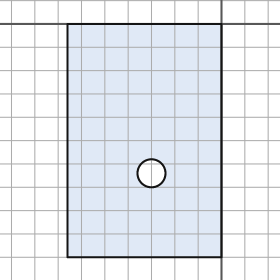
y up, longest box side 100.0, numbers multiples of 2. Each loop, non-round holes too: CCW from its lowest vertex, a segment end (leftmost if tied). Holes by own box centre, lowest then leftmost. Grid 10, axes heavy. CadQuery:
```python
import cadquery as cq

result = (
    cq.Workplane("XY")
    .moveTo(-66.0, -100.0)
    .lineTo(0.0, -100.0)
    .lineTo(0.0, 0.0)
    .lineTo(-66.0, 0.0)
    .close()
    .moveTo(-30.0, -64.0)
    .circle(6.0)
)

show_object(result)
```